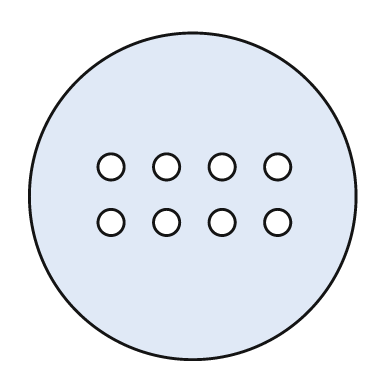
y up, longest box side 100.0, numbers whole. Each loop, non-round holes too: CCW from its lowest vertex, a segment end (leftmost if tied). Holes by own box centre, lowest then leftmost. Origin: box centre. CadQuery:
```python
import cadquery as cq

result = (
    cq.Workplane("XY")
    .moveTo(0.0, 0.0)
    .circle(50.0)
    .moveTo(-25.0, -8.0)
    .circle(4.0)
    .moveTo(-8.0, -8.0)
    .circle(4.0)
    .moveTo(9.0, -8.0)
    .circle(4.0)
    .moveTo(26.0, -8.0)
    .circle(4.0)
    .moveTo(-25.0, 9.0)
    .circle(4.0)
    .moveTo(-8.0, 9.0)
    .circle(4.0)
    .moveTo(9.0, 9.0)
    .circle(4.0)
    .moveTo(26.0, 9.0)
    .circle(4.0)
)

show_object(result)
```